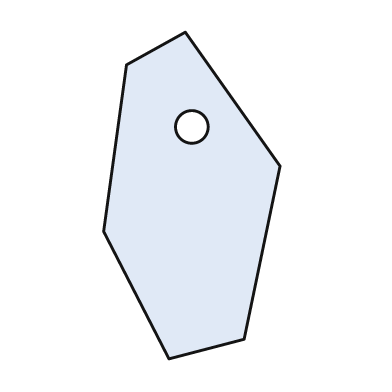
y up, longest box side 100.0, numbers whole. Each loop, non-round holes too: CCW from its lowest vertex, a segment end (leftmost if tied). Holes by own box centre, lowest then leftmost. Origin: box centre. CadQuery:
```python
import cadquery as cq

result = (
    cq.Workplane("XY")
    .moveTo(-7.0, -50.0)
    .lineTo(16.0, -44.0)
    .lineTo(27.0, 9.0)
    .lineTo(-2.0, 50.0)
    .lineTo(-20.0, 40.0)
    .lineTo(-27.0, -11.0)
    .close()
    .moveTo(0.0, 21.0)
    .circle(5.0)
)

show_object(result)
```